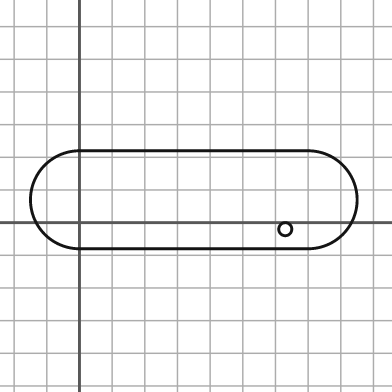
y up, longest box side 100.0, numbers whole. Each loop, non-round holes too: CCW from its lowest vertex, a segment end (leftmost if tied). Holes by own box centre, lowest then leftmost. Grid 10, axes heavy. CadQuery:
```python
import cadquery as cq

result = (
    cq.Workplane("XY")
    .moveTo(0.0, -8.0)
    .lineTo(70.0, -8.0)
    .threePointArc((85.0, 7.0), (70.0, 22.0))
    .lineTo(0.0, 22.0)
    .threePointArc((-15.0, 7.0), (0.0, -8.0))
    .close()
    .moveTo(63.0, -2.0)
    .circle(2.0)
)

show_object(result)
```